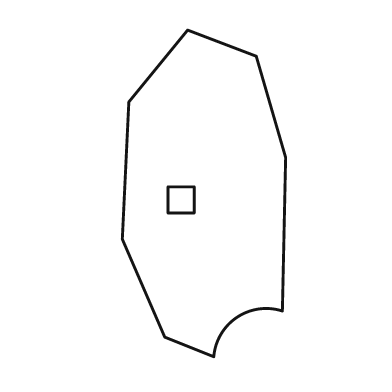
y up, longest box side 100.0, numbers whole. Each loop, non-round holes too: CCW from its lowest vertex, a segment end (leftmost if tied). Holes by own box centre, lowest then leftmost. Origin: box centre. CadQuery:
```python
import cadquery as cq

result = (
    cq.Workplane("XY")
    .moveTo(3.0, -50.0)
    .threePointArc((10.0, -38.0), (24.0, -36.0))
    .lineTo(25.0, 11.0)
    .lineTo(16.0, 42.0)
    .lineTo(-5.0, 50.0)
    .lineTo(-23.0, 28.0)
    .lineTo(-25.0, -14.0)
    .lineTo(-12.0, -44.0)
    .close()
    .moveTo(-11.0, -6.0)
    .lineTo(-3.0, -6.0)
    .lineTo(-3.0, 2.0)
    .lineTo(-11.0, 2.0)
    .close()
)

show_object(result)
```